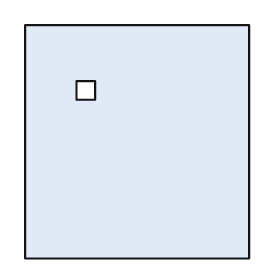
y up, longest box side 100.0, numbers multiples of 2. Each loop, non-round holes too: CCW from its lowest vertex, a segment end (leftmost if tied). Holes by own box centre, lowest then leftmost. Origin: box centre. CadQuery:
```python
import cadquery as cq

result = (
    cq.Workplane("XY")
    .moveTo(-48.0, -50.0)
    .lineTo(48.0, -50.0)
    .lineTo(48.0, 50.0)
    .lineTo(-48.0, 50.0)
    .close()
    .moveTo(-26.0, 18.0)
    .lineTo(-18.0, 18.0)
    .lineTo(-18.0, 26.0)
    .lineTo(-26.0, 26.0)
    .close()
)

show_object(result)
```